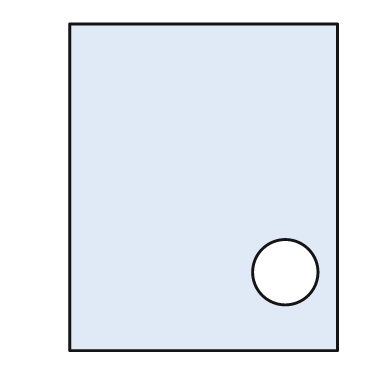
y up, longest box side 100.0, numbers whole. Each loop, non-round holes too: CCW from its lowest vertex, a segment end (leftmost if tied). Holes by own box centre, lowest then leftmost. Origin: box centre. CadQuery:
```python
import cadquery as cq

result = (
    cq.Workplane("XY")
    .moveTo(-41.0, -50.0)
    .lineTo(41.0, -50.0)
    .lineTo(41.0, 50.0)
    .lineTo(-41.0, 50.0)
    .close()
    .moveTo(25.0, -26.0)
    .circle(10.0)
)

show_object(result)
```